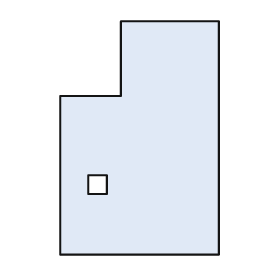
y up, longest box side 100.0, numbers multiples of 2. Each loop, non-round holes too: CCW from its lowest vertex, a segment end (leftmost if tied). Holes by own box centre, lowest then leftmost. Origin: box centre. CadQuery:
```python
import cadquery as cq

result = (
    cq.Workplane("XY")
    .moveTo(-34.0, -50.0)
    .lineTo(34.0, -50.0)
    .lineTo(34.0, 50.0)
    .lineTo(-8.0, 50.0)
    .lineTo(-8.0, 18.0)
    .lineTo(-34.0, 18.0)
    .close()
    .moveTo(-22.0, -24.0)
    .lineTo(-14.0, -24.0)
    .lineTo(-14.0, -16.0)
    .lineTo(-22.0, -16.0)
    .close()
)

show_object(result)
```